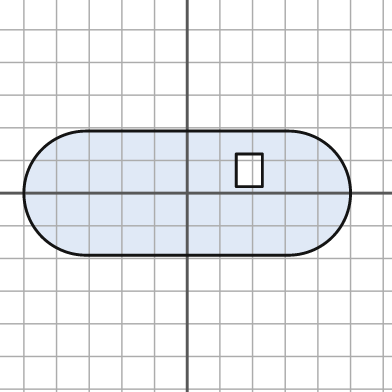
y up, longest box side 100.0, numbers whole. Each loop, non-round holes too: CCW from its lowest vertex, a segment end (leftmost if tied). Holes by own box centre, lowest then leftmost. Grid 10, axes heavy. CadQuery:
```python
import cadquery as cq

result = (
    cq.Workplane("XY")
    .moveTo(-31.0, -19.0)
    .lineTo(31.0, -19.0)
    .threePointArc((50.0, 0.0), (31.0, 19.0))
    .lineTo(-31.0, 19.0)
    .threePointArc((-50.0, 0.0), (-31.0, -19.0))
    .close()
    .moveTo(15.0, 2.0)
    .lineTo(23.0, 2.0)
    .lineTo(23.0, 12.0)
    .lineTo(15.0, 12.0)
    .close()
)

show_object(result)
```